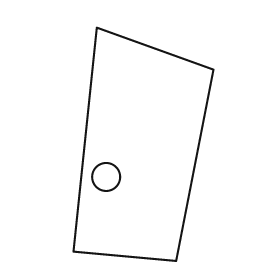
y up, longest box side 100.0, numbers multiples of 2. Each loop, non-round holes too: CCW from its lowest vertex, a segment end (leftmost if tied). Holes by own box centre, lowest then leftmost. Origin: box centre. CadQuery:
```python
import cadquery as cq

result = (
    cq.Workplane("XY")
    .moveTo(14.0, -50.0)
    .lineTo(30.0, 32.0)
    .lineTo(-20.0, 50.0)
    .lineTo(-30.0, -46.0)
    .close()
    .moveTo(-16.0, -14.0)
    .circle(6.0)
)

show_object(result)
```